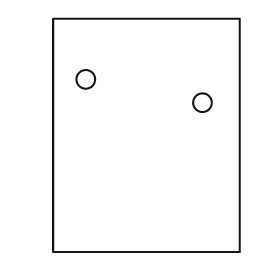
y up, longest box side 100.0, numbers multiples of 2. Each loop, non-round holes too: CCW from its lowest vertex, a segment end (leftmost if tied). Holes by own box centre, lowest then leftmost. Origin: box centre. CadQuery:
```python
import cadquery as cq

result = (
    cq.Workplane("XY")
    .moveTo(-40.0, -50.0)
    .lineTo(40.0, -50.0)
    .lineTo(40.0, 50.0)
    .lineTo(-40.0, 50.0)
    .close()
    .moveTo(24.0, 14.0)
    .circle(4.0)
    .moveTo(-26.0, 24.0)
    .circle(4.0)
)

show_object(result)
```